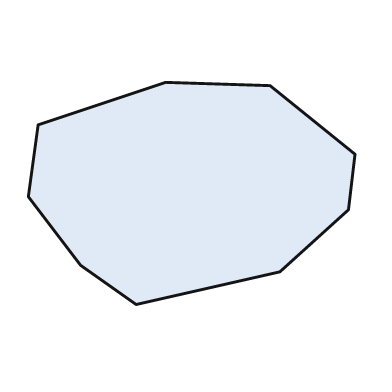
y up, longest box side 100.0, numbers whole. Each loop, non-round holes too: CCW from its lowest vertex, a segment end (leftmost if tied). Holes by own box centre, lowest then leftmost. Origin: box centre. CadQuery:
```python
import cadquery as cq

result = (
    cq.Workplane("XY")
    .moveTo(-17.0, -34.0)
    .lineTo(27.0, -24.0)
    .lineTo(48.0, -5.0)
    .lineTo(50.0, 12.0)
    .lineTo(24.0, 33.0)
    .lineTo(-8.0, 34.0)
    .lineTo(-47.0, 21.0)
    .lineTo(-50.0, -1.0)
    .lineTo(-34.0, -22.0)
    .close()
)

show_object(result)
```